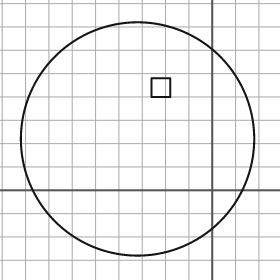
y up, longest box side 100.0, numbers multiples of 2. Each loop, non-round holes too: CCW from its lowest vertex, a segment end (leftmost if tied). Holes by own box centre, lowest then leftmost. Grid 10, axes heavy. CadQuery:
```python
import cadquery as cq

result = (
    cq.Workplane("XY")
    .moveTo(-32.0, 22.0)
    .circle(50.0)
    .moveTo(-26.0, 40.0)
    .lineTo(-18.0, 40.0)
    .lineTo(-18.0, 48.0)
    .lineTo(-26.0, 48.0)
    .close()
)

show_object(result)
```